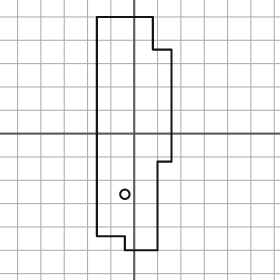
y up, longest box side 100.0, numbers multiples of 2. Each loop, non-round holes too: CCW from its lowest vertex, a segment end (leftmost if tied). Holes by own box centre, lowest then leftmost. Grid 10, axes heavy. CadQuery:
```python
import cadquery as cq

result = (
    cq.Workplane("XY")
    .moveTo(-4.0, -50.0)
    .lineTo(10.0, -50.0)
    .lineTo(10.0, -12.0)
    .lineTo(16.0, -12.0)
    .lineTo(16.0, 36.0)
    .lineTo(8.0, 36.0)
    .lineTo(8.0, 50.0)
    .lineTo(-16.0, 50.0)
    .lineTo(-16.0, -44.0)
    .lineTo(-4.0, -44.0)
    .close()
    .moveTo(-4.0, -26.0)
    .circle(2.0)
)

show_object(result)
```